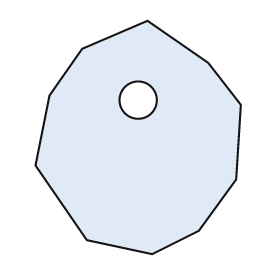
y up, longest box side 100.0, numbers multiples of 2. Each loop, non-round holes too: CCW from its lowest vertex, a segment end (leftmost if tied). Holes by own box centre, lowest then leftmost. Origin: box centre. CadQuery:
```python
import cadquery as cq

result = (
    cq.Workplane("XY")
    .moveTo(6.0, -50.0)
    .lineTo(26.0, -40.0)
    .lineTo(42.0, -18.0)
    .lineTo(44.0, 14.0)
    .lineTo(30.0, 32.0)
    .lineTo(4.0, 50.0)
    .lineTo(-24.0, 38.0)
    .lineTo(-38.0, 18.0)
    .lineTo(-44.0, -12.0)
    .lineTo(-22.0, -44.0)
    .close()
    .moveTo(0.0, 16.0)
    .circle(8.0)
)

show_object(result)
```